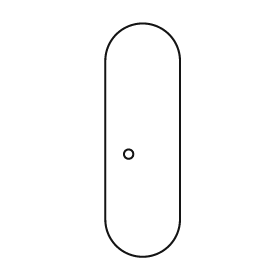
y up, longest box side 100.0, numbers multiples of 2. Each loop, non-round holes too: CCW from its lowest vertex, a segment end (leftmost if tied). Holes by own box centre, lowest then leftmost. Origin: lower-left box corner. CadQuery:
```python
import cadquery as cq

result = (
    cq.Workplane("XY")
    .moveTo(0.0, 16.0)
    .threePointArc((16.0, 0.0), (32.0, 16.0))
    .lineTo(32.0, 84.0)
    .threePointArc((16.0, 100.0), (0.0, 84.0))
    .close()
    .moveTo(10.0, 44.0)
    .circle(2.0)
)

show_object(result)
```